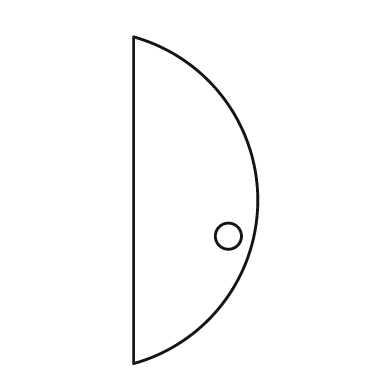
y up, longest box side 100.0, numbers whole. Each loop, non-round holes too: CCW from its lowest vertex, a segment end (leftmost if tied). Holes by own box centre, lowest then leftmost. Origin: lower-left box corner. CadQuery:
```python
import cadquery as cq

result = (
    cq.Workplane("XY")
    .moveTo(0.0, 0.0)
    .threePointArc((38.0, 50.0), (0.0, 100.0))
    .close()
    .moveTo(29.0, 39.0)
    .circle(4.0)
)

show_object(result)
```